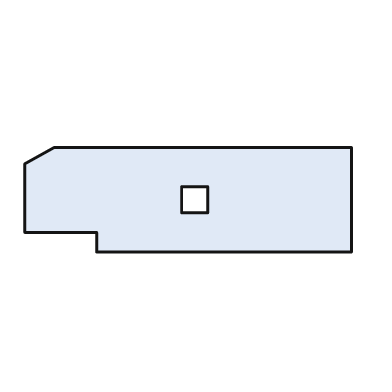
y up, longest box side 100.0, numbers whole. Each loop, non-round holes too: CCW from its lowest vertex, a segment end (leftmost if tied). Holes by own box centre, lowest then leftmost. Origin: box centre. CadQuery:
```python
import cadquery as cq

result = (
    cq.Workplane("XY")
    .moveTo(-28.0, -16.0)
    .lineTo(50.0, -16.0)
    .lineTo(50.0, 16.0)
    .lineTo(-41.0, 16.0)
    .lineTo(-50.0, 11.0)
    .lineTo(-50.0, -10.0)
    .lineTo(-28.0, -10.0)
    .close()
    .moveTo(-2.0, -4.0)
    .lineTo(6.0, -4.0)
    .lineTo(6.0, 4.0)
    .lineTo(-2.0, 4.0)
    .close()
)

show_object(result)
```